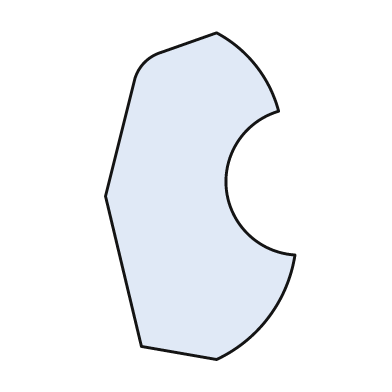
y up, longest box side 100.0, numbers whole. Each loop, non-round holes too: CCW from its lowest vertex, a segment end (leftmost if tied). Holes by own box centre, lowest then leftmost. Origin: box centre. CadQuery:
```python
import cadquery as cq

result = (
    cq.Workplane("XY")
    .moveTo(5.0, -50.0)
    .threePointArc((21.0, -37.0), (29.0, -18.0))
    .threePointArc((8.0, 2.0), (24.0, 26.0))
    .threePointArc((17.0, 40.0), (5.0, 50.0))
    .lineTo(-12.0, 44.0)
    .threePointArc((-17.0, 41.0), (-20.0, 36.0))
    .lineTo(-29.0, 0.0)
    .lineTo(-18.0, -46.0)
    .close()
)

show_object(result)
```